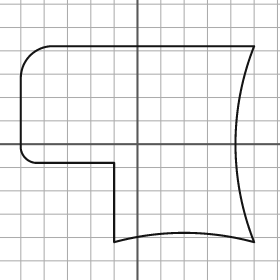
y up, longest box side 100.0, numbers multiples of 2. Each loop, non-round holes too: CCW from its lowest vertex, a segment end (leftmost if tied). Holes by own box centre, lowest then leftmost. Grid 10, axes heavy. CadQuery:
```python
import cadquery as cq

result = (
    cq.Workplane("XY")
    .moveTo(-10.0, -42.0)
    .threePointArc((20.0, -38.0), (50.0, -42.0))
    .threePointArc((42.0, 0.0), (50.0, 42.0))
    .lineTo(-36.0, 42.0)
    .threePointArc((-46.0, 38.0), (-50.0, 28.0))
    .lineTo(-50.0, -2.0)
    .threePointArc((-48.0, -6.0), (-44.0, -8.0))
    .lineTo(-10.0, -8.0)
    .close()
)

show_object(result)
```